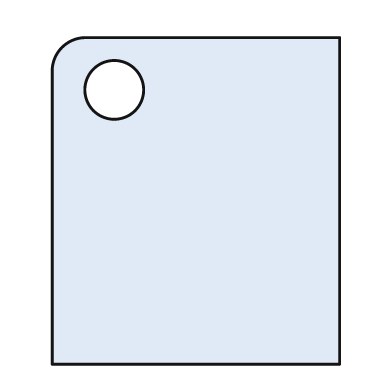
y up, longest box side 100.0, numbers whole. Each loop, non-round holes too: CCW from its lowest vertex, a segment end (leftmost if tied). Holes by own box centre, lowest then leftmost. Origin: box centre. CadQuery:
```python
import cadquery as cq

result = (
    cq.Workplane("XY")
    .moveTo(-44.0, -50.0)
    .lineTo(44.0, -50.0)
    .lineTo(44.0, 50.0)
    .lineTo(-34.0, 50.0)
    .threePointArc((-41.0, 47.0), (-44.0, 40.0))
    .close()
    .moveTo(-25.0, 34.0)
    .circle(9.0)
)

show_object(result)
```